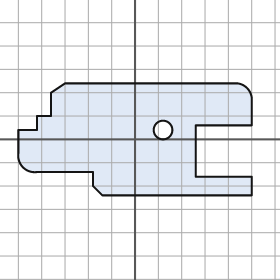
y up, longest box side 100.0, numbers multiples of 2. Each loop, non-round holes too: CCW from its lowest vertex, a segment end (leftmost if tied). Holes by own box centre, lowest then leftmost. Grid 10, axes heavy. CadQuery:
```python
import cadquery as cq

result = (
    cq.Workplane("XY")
    .moveTo(-14.0, -24.0)
    .lineTo(50.0, -24.0)
    .lineTo(50.0, -16.0)
    .lineTo(26.0, -16.0)
    .lineTo(26.0, 6.0)
    .lineTo(50.0, 6.0)
    .lineTo(50.0, 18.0)
    .threePointArc((48.0, 22.0), (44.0, 24.0))
    .lineTo(-30.0, 24.0)
    .lineTo(-36.0, 20.0)
    .lineTo(-36.0, 10.0)
    .lineTo(-42.0, 10.0)
    .lineTo(-42.0, 4.0)
    .lineTo(-50.0, 4.0)
    .lineTo(-50.0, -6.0)
    .threePointArc((-48.0, -12.0), (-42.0, -14.0))
    .lineTo(-18.0, -14.0)
    .lineTo(-18.0, -20.0)
    .close()
    .moveTo(12.0, 4.0)
    .circle(4.0)
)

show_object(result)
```